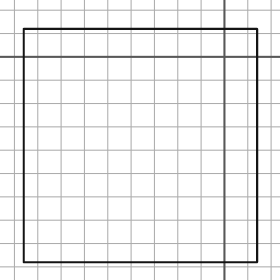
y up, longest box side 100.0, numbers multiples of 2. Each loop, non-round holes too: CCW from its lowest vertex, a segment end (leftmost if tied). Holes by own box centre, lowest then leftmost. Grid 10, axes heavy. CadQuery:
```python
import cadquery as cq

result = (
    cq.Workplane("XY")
    .moveTo(-86.0, -88.0)
    .lineTo(14.0, -88.0)
    .lineTo(14.0, 12.0)
    .lineTo(-86.0, 12.0)
    .close()
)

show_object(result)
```